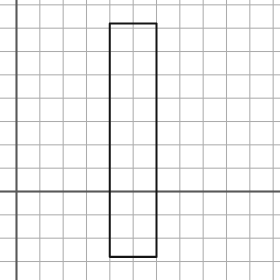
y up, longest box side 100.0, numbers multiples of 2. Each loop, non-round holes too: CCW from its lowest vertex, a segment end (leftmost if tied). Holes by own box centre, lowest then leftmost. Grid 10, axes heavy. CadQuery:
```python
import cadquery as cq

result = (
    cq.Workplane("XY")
    .moveTo(40.0, -28.0)
    .lineTo(60.0, -28.0)
    .lineTo(60.0, 72.0)
    .lineTo(40.0, 72.0)
    .close()
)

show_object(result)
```